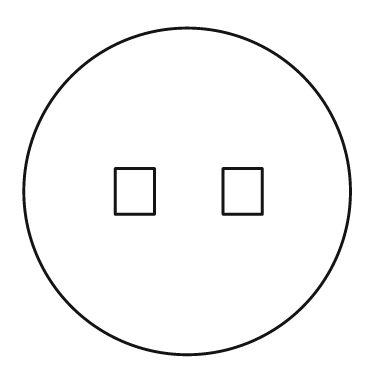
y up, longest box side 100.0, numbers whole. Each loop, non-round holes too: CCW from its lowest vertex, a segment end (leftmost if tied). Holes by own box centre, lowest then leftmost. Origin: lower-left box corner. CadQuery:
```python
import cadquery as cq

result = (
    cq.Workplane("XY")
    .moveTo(50.0, 50.0)
    .circle(50.0)
    .moveTo(28.0, 43.0)
    .lineTo(40.0, 43.0)
    .lineTo(40.0, 57.0)
    .lineTo(28.0, 57.0)
    .close()
    .moveTo(61.0, 43.0)
    .lineTo(73.0, 43.0)
    .lineTo(73.0, 57.0)
    .lineTo(61.0, 57.0)
    .close()
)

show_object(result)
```